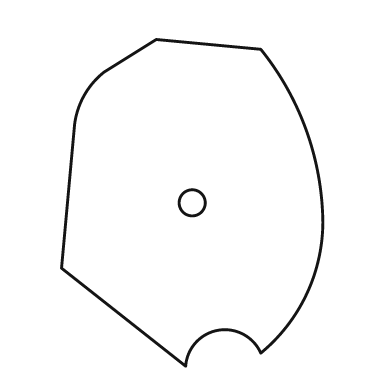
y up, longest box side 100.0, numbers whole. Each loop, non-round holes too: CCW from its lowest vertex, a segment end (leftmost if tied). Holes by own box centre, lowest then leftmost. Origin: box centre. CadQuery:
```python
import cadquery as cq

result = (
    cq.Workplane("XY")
    .moveTo(-2.0, -50.0)
    .threePointArc((8.0, -39.0), (21.0, -46.0))
    .threePointArc((35.0, -28.0), (40.0, -6.0))
    .threePointArc((35.0, 22.0), (21.0, 47.0))
    .lineTo(-11.0, 50.0)
    .lineTo(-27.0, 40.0)
    .threePointArc((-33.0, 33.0), (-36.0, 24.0))
    .lineTo(-40.0, -20.0)
    .close()
    .moveTo(0.0, 0.0)
    .circle(4.0)
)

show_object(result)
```